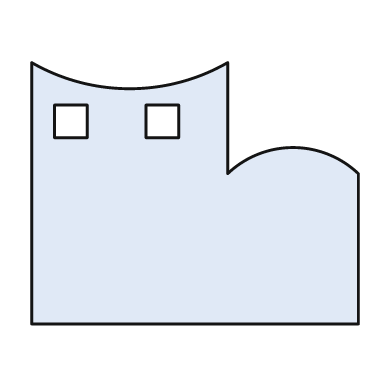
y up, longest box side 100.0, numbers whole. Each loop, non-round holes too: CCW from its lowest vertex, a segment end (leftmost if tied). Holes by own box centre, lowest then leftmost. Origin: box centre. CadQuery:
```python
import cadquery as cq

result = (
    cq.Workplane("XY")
    .moveTo(-50.0, -40.0)
    .lineTo(50.0, -40.0)
    .lineTo(50.0, 6.0)
    .threePointArc((30.0, 14.0), (10.0, 6.0))
    .lineTo(10.0, 40.0)
    .threePointArc((-20.0, 32.0), (-50.0, 40.0))
    .close()
    .moveTo(-43.0, 17.0)
    .lineTo(-33.0, 17.0)
    .lineTo(-33.0, 27.0)
    .lineTo(-43.0, 27.0)
    .close()
    .moveTo(-15.0, 17.0)
    .lineTo(-5.0, 17.0)
    .lineTo(-5.0, 27.0)
    .lineTo(-15.0, 27.0)
    .close()
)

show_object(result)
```